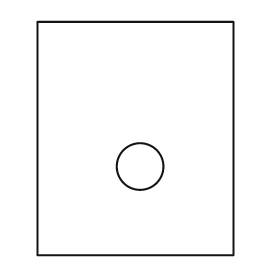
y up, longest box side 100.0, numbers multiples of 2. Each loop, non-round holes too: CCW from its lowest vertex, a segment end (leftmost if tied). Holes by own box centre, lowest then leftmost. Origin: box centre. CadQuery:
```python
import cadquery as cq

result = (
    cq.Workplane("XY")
    .moveTo(-42.0, -50.0)
    .lineTo(42.0, -50.0)
    .lineTo(42.0, 50.0)
    .lineTo(-42.0, 50.0)
    .close()
    .moveTo(2.0, -12.0)
    .circle(10.0)
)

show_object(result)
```